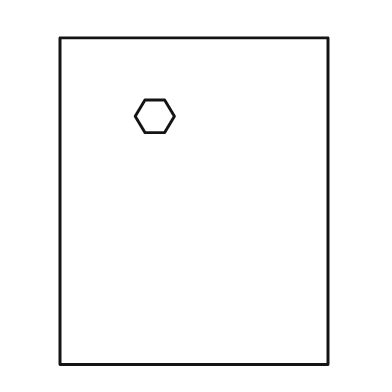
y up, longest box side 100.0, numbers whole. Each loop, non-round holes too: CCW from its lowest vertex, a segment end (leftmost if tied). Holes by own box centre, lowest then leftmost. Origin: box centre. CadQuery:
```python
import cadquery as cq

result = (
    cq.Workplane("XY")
    .moveTo(-41.0, -50.0)
    .lineTo(41.0, -50.0)
    .lineTo(41.0, 50.0)
    .lineTo(-41.0, 50.0)
    .close()
    .moveTo(-15.0, 21.0)
    .lineTo(-9.0, 21.0)
    .lineTo(-6.0, 26.0)
    .lineTo(-9.0, 31.0)
    .lineTo(-15.0, 31.0)
    .lineTo(-18.0, 26.0)
    .close()
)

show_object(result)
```